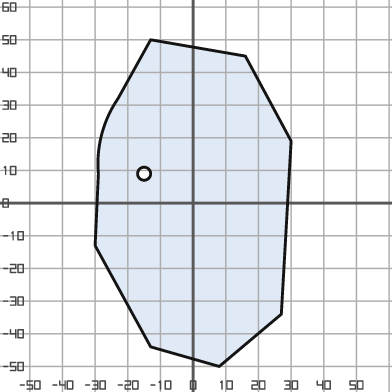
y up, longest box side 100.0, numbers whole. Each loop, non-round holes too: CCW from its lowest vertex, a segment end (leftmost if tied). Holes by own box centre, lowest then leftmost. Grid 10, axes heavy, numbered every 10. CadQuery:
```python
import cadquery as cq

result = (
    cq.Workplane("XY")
    .moveTo(8.0, -50.0)
    .lineTo(27.0, -34.0)
    .lineTo(30.0, 19.0)
    .lineTo(16.0, 45.0)
    .lineTo(-13.0, 50.0)
    .lineTo(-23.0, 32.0)
    .threePointArc((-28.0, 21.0), (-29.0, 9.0))
    .lineTo(-30.0, -13.0)
    .lineTo(-13.0, -44.0)
    .close()
    .moveTo(-15.0, 9.0)
    .circle(2.0)
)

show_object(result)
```